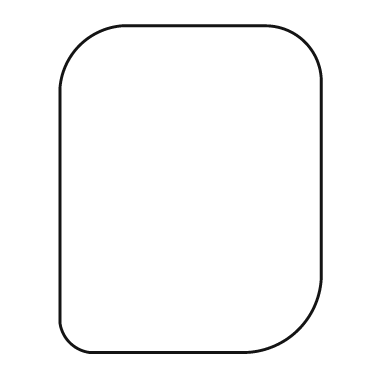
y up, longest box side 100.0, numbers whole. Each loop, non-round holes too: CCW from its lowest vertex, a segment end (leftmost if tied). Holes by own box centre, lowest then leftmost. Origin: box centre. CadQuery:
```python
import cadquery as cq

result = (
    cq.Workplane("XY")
    .moveTo(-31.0, -50.0)
    .lineTo(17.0, -50.0)
    .threePointArc((33.0, -43.0), (40.0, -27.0))
    .lineTo(40.0, 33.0)
    .threePointArc((35.0, 45.0), (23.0, 50.0))
    .lineTo(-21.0, 50.0)
    .threePointArc((-34.0, 44.0), (-40.0, 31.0))
    .lineTo(-40.0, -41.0)
    .threePointArc((-37.0, -47.0), (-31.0, -50.0))
    .close()
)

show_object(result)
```